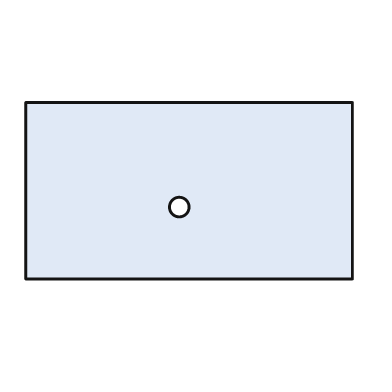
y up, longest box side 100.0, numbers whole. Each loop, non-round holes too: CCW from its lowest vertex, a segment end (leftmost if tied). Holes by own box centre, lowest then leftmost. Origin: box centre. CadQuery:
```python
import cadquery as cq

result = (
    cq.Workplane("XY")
    .moveTo(-50.0, -27.0)
    .lineTo(50.0, -27.0)
    .lineTo(50.0, 27.0)
    .lineTo(-50.0, 27.0)
    .close()
    .moveTo(-3.0, -5.0)
    .circle(3.0)
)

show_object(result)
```